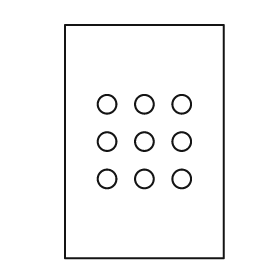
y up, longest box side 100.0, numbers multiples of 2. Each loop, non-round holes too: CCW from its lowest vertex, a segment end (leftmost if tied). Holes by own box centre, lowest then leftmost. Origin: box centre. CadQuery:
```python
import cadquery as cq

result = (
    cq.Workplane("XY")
    .moveTo(-34.0, -50.0)
    .lineTo(34.0, -50.0)
    .lineTo(34.0, 50.0)
    .lineTo(-34.0, 50.0)
    .close()
    .moveTo(-16.0, -16.0)
    .circle(4.0)
    .moveTo(0.0, -16.0)
    .circle(4.0)
    .moveTo(16.0, -16.0)
    .circle(4.0)
    .moveTo(-16.0, 0.0)
    .circle(4.0)
    .moveTo(0.0, 0.0)
    .circle(4.0)
    .moveTo(16.0, 0.0)
    .circle(4.0)
    .moveTo(-16.0, 16.0)
    .circle(4.0)
    .moveTo(0.0, 16.0)
    .circle(4.0)
    .moveTo(16.0, 16.0)
    .circle(4.0)
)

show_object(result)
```